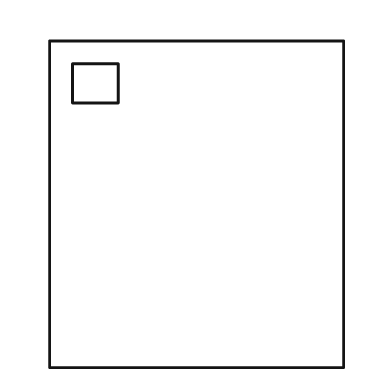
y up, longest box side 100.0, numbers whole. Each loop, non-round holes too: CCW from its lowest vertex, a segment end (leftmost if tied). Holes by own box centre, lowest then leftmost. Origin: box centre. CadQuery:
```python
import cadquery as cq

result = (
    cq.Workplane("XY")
    .moveTo(-45.0, -50.0)
    .lineTo(45.0, -50.0)
    .lineTo(45.0, 50.0)
    .lineTo(-45.0, 50.0)
    .close()
    .moveTo(-38.0, 31.0)
    .lineTo(-24.0, 31.0)
    .lineTo(-24.0, 43.0)
    .lineTo(-38.0, 43.0)
    .close()
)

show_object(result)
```